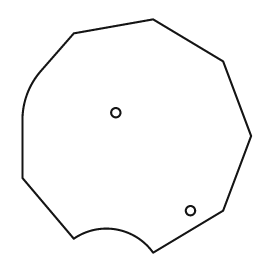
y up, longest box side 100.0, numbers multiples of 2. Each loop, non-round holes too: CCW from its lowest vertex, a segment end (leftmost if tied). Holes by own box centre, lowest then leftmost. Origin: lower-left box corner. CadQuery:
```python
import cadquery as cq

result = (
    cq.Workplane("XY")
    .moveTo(56.0, 0.0)
    .lineTo(86.0, 18.0)
    .lineTo(98.0, 50.0)
    .lineTo(86.0, 82.0)
    .lineTo(56.0, 100.0)
    .lineTo(22.0, 94.0)
    .lineTo(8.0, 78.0)
    .threePointArc((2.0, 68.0), (0.0, 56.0))
    .lineTo(0.0, 32.0)
    .lineTo(22.0, 6.0)
    .threePointArc((40.0, 10.0), (56.0, 0.0))
    .close()
    .moveTo(72.0, 18.0)
    .circle(2.0)
    .moveTo(40.0, 60.0)
    .circle(2.0)
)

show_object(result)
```